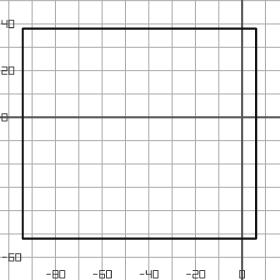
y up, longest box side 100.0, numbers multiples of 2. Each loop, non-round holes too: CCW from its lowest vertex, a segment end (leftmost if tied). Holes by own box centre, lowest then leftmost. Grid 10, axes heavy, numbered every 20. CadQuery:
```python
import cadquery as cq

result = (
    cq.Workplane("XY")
    .moveTo(-94.0, -52.0)
    .lineTo(6.0, -52.0)
    .lineTo(6.0, 38.0)
    .lineTo(-94.0, 38.0)
    .close()
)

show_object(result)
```